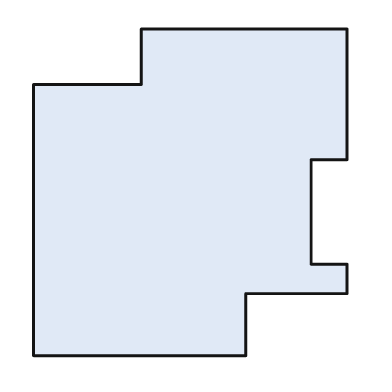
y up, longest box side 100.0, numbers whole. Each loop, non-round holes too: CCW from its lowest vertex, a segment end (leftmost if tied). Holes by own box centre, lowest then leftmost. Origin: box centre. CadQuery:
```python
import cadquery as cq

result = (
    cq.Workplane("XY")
    .moveTo(-48.0, -50.0)
    .lineTo(17.0, -50.0)
    .lineTo(17.0, -31.0)
    .lineTo(48.0, -31.0)
    .lineTo(48.0, -22.0)
    .lineTo(37.0, -22.0)
    .lineTo(37.0, 10.0)
    .lineTo(48.0, 10.0)
    .lineTo(48.0, 50.0)
    .lineTo(-15.0, 50.0)
    .lineTo(-15.0, 33.0)
    .lineTo(-48.0, 33.0)
    .close()
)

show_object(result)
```